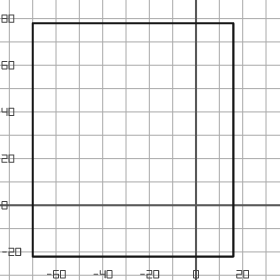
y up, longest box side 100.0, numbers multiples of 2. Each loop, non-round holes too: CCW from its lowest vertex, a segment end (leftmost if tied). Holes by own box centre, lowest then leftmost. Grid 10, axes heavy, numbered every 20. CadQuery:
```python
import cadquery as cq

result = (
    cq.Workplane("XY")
    .moveTo(-70.0, -22.0)
    .lineTo(16.0, -22.0)
    .lineTo(16.0, 78.0)
    .lineTo(-70.0, 78.0)
    .close()
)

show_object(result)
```